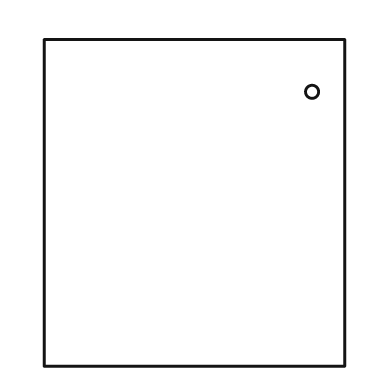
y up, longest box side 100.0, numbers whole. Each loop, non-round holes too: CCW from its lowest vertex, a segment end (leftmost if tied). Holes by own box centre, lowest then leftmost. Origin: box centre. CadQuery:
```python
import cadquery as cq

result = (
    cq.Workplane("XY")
    .moveTo(-46.0, -50.0)
    .lineTo(46.0, -50.0)
    .lineTo(46.0, 50.0)
    .lineTo(-46.0, 50.0)
    .close()
    .moveTo(36.0, 34.0)
    .circle(2.0)
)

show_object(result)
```